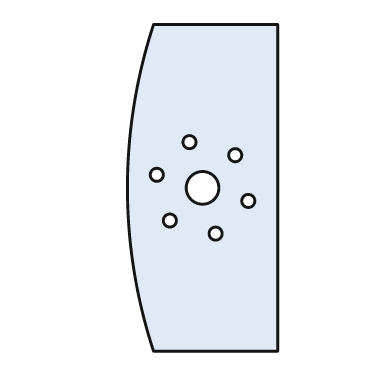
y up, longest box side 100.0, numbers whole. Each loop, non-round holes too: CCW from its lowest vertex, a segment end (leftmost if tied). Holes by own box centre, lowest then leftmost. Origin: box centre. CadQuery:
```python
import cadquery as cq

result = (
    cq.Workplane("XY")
    .moveTo(-15.0, -50.0)
    .lineTo(23.0, -50.0)
    .lineTo(23.0, 50.0)
    .lineTo(-15.0, 50.0)
    .threePointArc((-23.0, 0.0), (-15.0, -50.0))
    .close()
    .moveTo(4.0, -14.0)
    .circle(2.0)
    .moveTo(-10.0, -10.0)
    .circle(2.0)
    .moveTo(14.0, -4.0)
    .circle(2.0)
    .moveTo(0.0, 0.0)
    .circle(5.0)
    .moveTo(-14.0, 4.0)
    .circle(2.0)
    .moveTo(10.0, 10.0)
    .circle(2.0)
    .moveTo(-4.0, 14.0)
    .circle(2.0)
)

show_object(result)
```